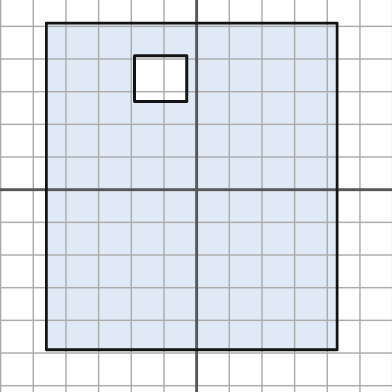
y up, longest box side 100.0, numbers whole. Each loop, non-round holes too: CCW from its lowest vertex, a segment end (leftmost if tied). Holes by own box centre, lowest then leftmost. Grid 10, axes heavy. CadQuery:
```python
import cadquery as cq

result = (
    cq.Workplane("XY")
    .moveTo(-46.0, -49.0)
    .lineTo(43.0, -49.0)
    .lineTo(43.0, 51.0)
    .lineTo(-46.0, 51.0)
    .close()
    .moveTo(-19.0, 27.0)
    .lineTo(-3.0, 27.0)
    .lineTo(-3.0, 41.0)
    .lineTo(-19.0, 41.0)
    .close()
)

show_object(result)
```